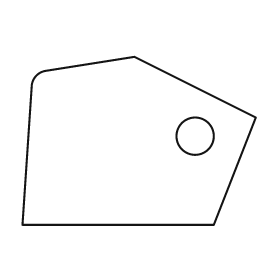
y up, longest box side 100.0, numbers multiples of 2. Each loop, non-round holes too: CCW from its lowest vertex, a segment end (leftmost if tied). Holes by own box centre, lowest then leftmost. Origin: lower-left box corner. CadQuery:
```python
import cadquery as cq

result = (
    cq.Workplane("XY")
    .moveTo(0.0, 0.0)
    .lineTo(82.0, 0.0)
    .lineTo(100.0, 46.0)
    .lineTo(48.0, 72.0)
    .lineTo(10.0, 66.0)
    .threePointArc((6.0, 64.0), (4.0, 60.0))
    .close()
    .moveTo(74.0, 38.0)
    .circle(8.0)
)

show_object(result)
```